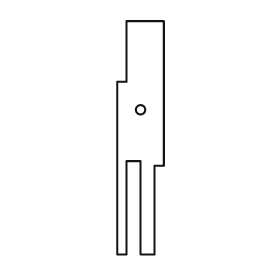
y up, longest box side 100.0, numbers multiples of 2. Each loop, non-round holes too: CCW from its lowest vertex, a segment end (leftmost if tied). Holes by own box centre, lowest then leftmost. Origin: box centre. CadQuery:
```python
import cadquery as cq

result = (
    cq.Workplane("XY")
    .moveTo(-10.0, -50.0)
    .lineTo(-6.0, -50.0)
    .lineTo(-6.0, -10.0)
    .lineTo(0.0, -10.0)
    .lineTo(0.0, -50.0)
    .lineTo(6.0, -50.0)
    .lineTo(6.0, -12.0)
    .lineTo(10.0, -12.0)
    .lineTo(10.0, 50.0)
    .lineTo(-6.0, 50.0)
    .lineTo(-6.0, 24.0)
    .lineTo(-10.0, 24.0)
    .close()
    .moveTo(0.0, 12.0)
    .circle(2.0)
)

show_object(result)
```